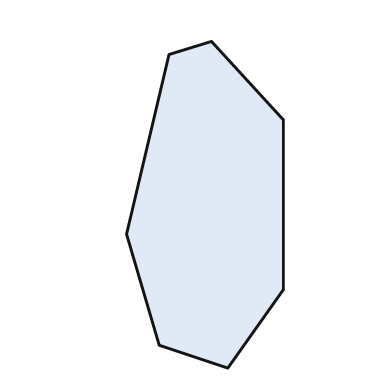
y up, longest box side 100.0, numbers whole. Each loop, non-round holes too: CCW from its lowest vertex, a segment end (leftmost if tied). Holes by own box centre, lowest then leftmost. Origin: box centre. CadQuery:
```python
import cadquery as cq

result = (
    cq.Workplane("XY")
    .moveTo(7.0, -50.0)
    .lineTo(24.0, -26.0)
    .lineTo(24.0, 26.0)
    .lineTo(2.0, 50.0)
    .lineTo(-11.0, 46.0)
    .lineTo(-24.0, -9.0)
    .lineTo(-14.0, -43.0)
    .close()
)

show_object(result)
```